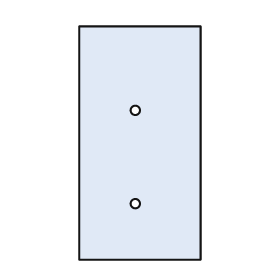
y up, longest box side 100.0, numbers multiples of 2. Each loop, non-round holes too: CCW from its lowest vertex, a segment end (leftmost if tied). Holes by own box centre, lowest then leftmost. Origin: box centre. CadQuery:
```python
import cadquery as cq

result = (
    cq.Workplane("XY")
    .moveTo(-26.0, -50.0)
    .lineTo(26.0, -50.0)
    .lineTo(26.0, 50.0)
    .lineTo(-26.0, 50.0)
    .close()
    .moveTo(-2.0, -26.0)
    .circle(2.0)
    .moveTo(-2.0, 14.0)
    .circle(2.0)
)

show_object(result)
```